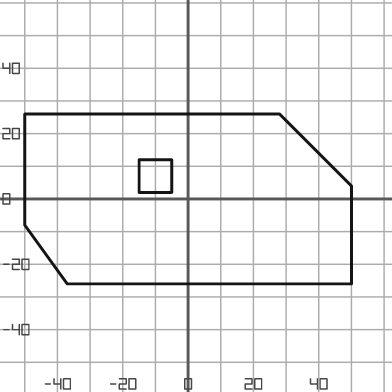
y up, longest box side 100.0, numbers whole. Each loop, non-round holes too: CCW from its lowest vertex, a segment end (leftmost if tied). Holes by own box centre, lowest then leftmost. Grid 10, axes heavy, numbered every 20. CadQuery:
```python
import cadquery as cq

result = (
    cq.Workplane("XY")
    .moveTo(-37.0, -26.0)
    .lineTo(50.0, -26.0)
    .lineTo(50.0, 4.0)
    .lineTo(28.0, 26.0)
    .lineTo(-50.0, 26.0)
    .lineTo(-50.0, -8.0)
    .close()
    .moveTo(-15.0, 2.0)
    .lineTo(-5.0, 2.0)
    .lineTo(-5.0, 12.0)
    .lineTo(-15.0, 12.0)
    .close()
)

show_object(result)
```